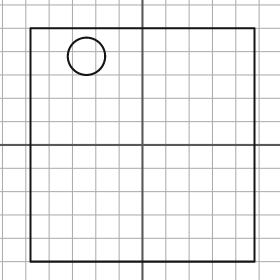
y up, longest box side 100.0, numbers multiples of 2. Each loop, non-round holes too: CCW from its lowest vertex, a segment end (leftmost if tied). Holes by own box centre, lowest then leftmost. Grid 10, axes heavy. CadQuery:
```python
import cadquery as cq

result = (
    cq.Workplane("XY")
    .moveTo(-48.0, -50.0)
    .lineTo(48.0, -50.0)
    .lineTo(48.0, 50.0)
    .lineTo(-48.0, 50.0)
    .close()
    .moveTo(-24.0, 38.0)
    .circle(8.0)
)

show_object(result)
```